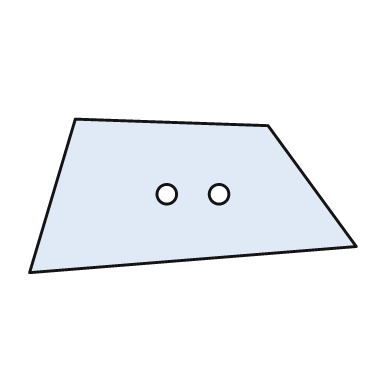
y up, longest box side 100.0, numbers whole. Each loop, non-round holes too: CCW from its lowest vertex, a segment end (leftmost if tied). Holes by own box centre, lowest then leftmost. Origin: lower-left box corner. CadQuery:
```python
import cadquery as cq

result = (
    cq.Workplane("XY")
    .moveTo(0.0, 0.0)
    .lineTo(100.0, 8.0)
    .lineTo(73.0, 45.0)
    .lineTo(14.0, 47.0)
    .close()
    .moveTo(42.0, 24.0)
    .circle(3.0)
    .moveTo(58.0, 24.0)
    .circle(3.0)
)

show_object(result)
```